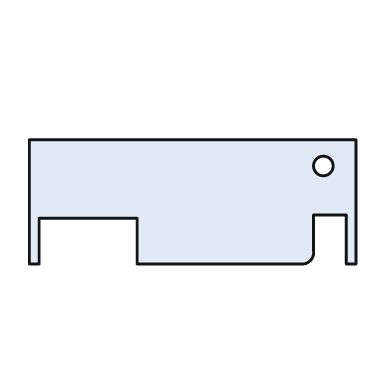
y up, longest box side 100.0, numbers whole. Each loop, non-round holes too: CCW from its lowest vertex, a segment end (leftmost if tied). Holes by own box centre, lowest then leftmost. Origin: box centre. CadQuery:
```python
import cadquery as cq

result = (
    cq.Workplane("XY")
    .moveTo(-50.0, -19.0)
    .lineTo(-47.0, -19.0)
    .lineTo(-47.0, -5.0)
    .lineTo(-17.0, -5.0)
    .lineTo(-17.0, -19.0)
    .lineTo(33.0, -19.0)
    .threePointArc((36.0, -18.0), (37.0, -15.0))
    .lineTo(37.0, -4.0)
    .lineTo(47.0, -4.0)
    .lineTo(47.0, -19.0)
    .lineTo(50.0, -19.0)
    .lineTo(50.0, 19.0)
    .lineTo(-50.0, 19.0)
    .close()
    .moveTo(40.0, 11.0)
    .circle(3.0)
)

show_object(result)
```